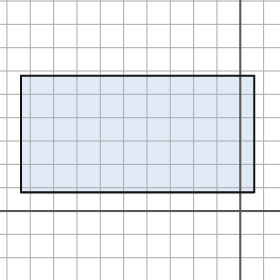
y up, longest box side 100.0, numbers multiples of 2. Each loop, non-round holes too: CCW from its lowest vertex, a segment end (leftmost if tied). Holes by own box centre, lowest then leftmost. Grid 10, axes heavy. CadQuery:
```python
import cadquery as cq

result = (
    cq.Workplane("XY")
    .moveTo(-94.0, 8.0)
    .lineTo(6.0, 8.0)
    .lineTo(6.0, 58.0)
    .lineTo(-94.0, 58.0)
    .close()
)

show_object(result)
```